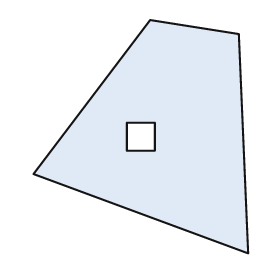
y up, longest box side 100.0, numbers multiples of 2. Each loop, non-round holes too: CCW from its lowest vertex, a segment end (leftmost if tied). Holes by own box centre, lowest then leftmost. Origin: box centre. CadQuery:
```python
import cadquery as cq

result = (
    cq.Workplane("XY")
    .moveTo(46.0, -50.0)
    .lineTo(42.0, 44.0)
    .lineTo(4.0, 50.0)
    .lineTo(-46.0, -16.0)
    .close()
    .moveTo(-6.0, -6.0)
    .lineTo(6.0, -6.0)
    .lineTo(6.0, 6.0)
    .lineTo(-6.0, 6.0)
    .close()
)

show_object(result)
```